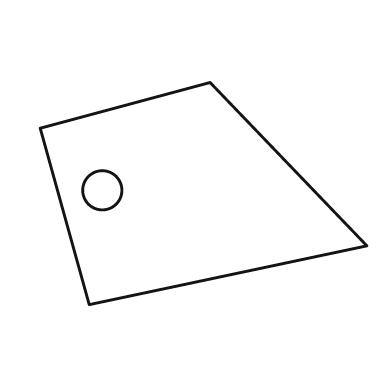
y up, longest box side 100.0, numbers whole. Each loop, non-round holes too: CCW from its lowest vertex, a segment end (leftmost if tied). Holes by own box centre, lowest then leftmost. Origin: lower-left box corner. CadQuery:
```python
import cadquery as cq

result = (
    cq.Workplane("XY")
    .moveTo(15.0, 0.0)
    .lineTo(100.0, 18.0)
    .lineTo(52.0, 68.0)
    .lineTo(0.0, 54.0)
    .close()
    .moveTo(19.0, 35.0)
    .circle(6.0)
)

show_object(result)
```